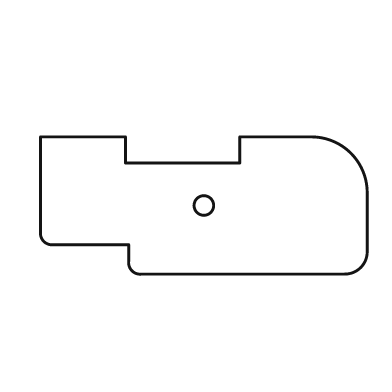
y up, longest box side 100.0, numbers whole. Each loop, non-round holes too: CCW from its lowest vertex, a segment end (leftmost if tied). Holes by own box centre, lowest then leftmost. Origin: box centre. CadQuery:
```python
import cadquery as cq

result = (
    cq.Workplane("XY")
    .moveTo(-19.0, -21.0)
    .lineTo(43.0, -21.0)
    .threePointArc((48.0, -19.0), (50.0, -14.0))
    .lineTo(50.0, 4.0)
    .threePointArc((45.0, 16.0), (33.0, 21.0))
    .lineTo(11.0, 21.0)
    .lineTo(11.0, 13.0)
    .lineTo(-24.0, 13.0)
    .lineTo(-24.0, 21.0)
    .lineTo(-50.0, 21.0)
    .lineTo(-50.0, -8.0)
    .threePointArc((-49.0, -11.0), (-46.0, -12.0))
    .lineTo(-23.0, -12.0)
    .lineTo(-23.0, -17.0)
    .threePointArc((-22.0, -20.0), (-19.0, -21.0))
    .close()
    .moveTo(0.0, 0.0)
    .circle(3.0)
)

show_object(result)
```